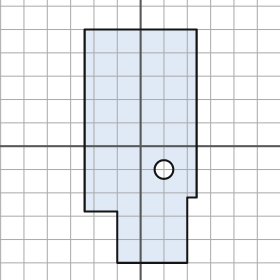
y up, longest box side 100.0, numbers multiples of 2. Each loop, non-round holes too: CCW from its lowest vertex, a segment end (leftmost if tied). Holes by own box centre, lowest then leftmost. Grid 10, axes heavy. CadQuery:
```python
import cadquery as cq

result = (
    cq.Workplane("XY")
    .moveTo(-10.0, -50.0)
    .lineTo(20.0, -50.0)
    .lineTo(20.0, -22.0)
    .lineTo(24.0, -22.0)
    .lineTo(24.0, 50.0)
    .lineTo(-24.0, 50.0)
    .lineTo(-24.0, -28.0)
    .lineTo(-10.0, -28.0)
    .close()
    .moveTo(10.0, -10.0)
    .circle(4.0)
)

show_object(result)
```